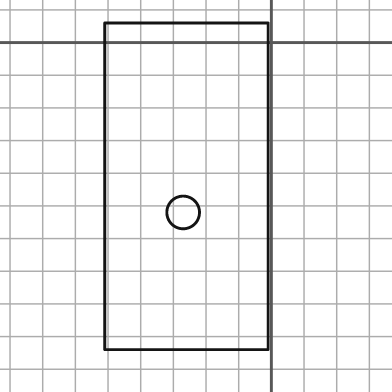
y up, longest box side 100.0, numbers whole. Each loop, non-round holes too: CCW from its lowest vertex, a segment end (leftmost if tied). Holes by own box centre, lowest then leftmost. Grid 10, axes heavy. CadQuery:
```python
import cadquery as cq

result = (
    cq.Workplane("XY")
    .moveTo(-51.0, -94.0)
    .lineTo(-1.0, -94.0)
    .lineTo(-1.0, 6.0)
    .lineTo(-51.0, 6.0)
    .close()
    .moveTo(-27.0, -52.0)
    .circle(5.0)
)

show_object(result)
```